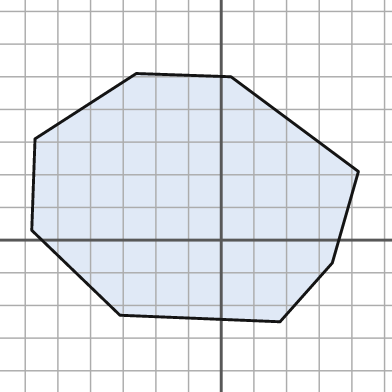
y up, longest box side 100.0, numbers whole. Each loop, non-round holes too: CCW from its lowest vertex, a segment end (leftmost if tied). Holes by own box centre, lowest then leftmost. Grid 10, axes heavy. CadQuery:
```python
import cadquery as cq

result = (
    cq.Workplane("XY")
    .moveTo(18.0, -25.0)
    .lineTo(34.0, -7.0)
    .lineTo(42.0, 21.0)
    .lineTo(3.0, 50.0)
    .lineTo(-26.0, 51.0)
    .lineTo(-57.0, 31.0)
    .lineTo(-58.0, 3.0)
    .lineTo(-31.0, -23.0)
    .close()
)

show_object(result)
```